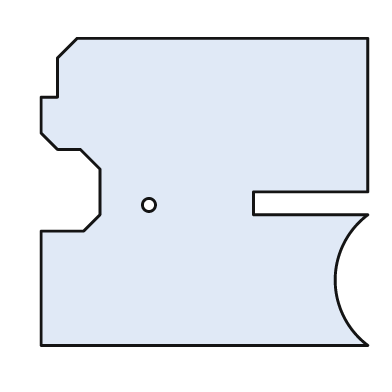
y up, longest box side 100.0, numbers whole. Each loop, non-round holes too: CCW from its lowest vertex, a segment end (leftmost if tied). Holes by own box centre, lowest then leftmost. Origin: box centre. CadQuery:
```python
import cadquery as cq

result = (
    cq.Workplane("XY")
    .moveTo(-50.0, -47.0)
    .lineTo(50.0, -47.0)
    .threePointArc((40.0, -27.0), (50.0, -7.0))
    .lineTo(15.0, -7.0)
    .lineTo(15.0, 0.0)
    .lineTo(50.0, 0.0)
    .lineTo(50.0, 47.0)
    .lineTo(-39.0, 47.0)
    .lineTo(-45.0, 41.0)
    .lineTo(-45.0, 29.0)
    .lineTo(-50.0, 29.0)
    .lineTo(-50.0, 18.0)
    .lineTo(-45.0, 13.0)
    .lineTo(-38.0, 13.0)
    .lineTo(-32.0, 7.0)
    .lineTo(-32.0, -7.0)
    .lineTo(-37.0, -12.0)
    .lineTo(-50.0, -12.0)
    .close()
    .moveTo(-17.0, -4.0)
    .circle(2.0)
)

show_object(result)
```